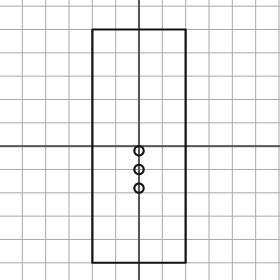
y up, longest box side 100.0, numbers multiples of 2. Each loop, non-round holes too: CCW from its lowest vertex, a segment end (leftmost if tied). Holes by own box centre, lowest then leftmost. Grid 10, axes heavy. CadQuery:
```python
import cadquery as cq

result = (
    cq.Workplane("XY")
    .moveTo(-20.0, -50.0)
    .lineTo(20.0, -50.0)
    .lineTo(20.0, 50.0)
    .lineTo(-20.0, 50.0)
    .close()
    .moveTo(0.0, -18.0)
    .circle(2.0)
    .moveTo(0.0, -10.0)
    .circle(2.0)
    .moveTo(0.0, -2.0)
    .circle(2.0)
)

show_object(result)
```